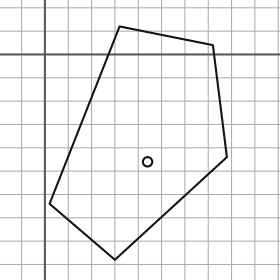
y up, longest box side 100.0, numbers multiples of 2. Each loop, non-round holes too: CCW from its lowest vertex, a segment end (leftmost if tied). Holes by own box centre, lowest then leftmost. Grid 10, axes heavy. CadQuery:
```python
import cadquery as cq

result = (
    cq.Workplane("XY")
    .moveTo(30.0, -88.0)
    .lineTo(78.0, -44.0)
    .lineTo(72.0, 4.0)
    .lineTo(32.0, 12.0)
    .lineTo(2.0, -64.0)
    .close()
    .moveTo(44.0, -46.0)
    .circle(2.0)
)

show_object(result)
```